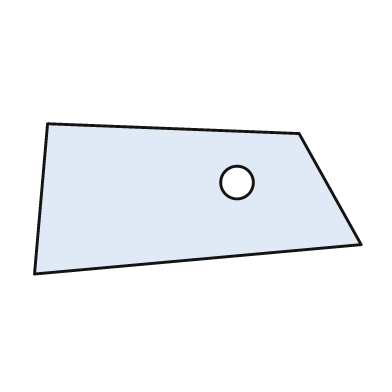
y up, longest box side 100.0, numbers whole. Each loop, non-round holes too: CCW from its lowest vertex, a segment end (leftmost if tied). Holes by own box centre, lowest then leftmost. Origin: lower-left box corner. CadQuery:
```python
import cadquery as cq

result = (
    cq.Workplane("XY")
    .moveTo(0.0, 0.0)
    .lineTo(100.0, 9.0)
    .lineTo(81.0, 43.0)
    .lineTo(4.0, 46.0)
    .close()
    .moveTo(62.0, 28.0)
    .circle(5.0)
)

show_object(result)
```